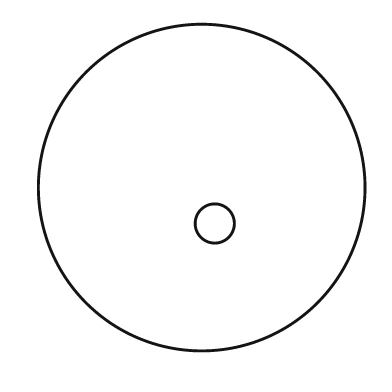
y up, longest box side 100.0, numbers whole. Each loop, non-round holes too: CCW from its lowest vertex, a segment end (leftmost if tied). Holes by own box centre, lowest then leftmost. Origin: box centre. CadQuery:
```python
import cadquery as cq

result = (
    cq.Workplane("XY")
    .moveTo(0.0, 0.0)
    .circle(50.0)
    .moveTo(4.0, -11.0)
    .circle(6.0)
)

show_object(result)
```